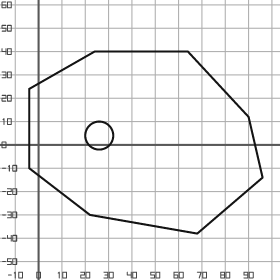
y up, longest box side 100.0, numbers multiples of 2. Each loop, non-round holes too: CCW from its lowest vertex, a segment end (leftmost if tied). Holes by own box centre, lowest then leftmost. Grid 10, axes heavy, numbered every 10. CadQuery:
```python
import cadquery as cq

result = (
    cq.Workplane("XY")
    .moveTo(68.0, -38.0)
    .lineTo(96.0, -14.0)
    .lineTo(90.0, 12.0)
    .lineTo(64.0, 40.0)
    .lineTo(24.0, 40.0)
    .lineTo(-4.0, 24.0)
    .lineTo(-4.0, -10.0)
    .lineTo(22.0, -30.0)
    .close()
    .moveTo(26.0, 4.0)
    .circle(6.0)
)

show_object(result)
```